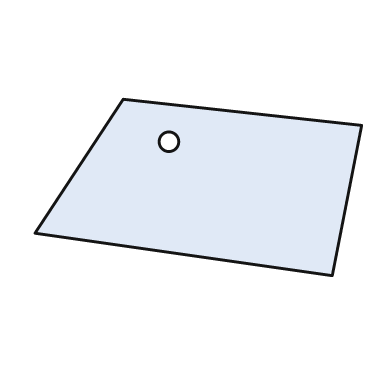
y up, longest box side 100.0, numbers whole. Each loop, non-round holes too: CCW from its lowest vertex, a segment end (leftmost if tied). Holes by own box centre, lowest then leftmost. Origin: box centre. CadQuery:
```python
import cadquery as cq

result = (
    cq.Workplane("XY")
    .moveTo(41.0, -27.0)
    .lineTo(50.0, 19.0)
    .lineTo(-23.0, 27.0)
    .lineTo(-50.0, -14.0)
    .close()
    .moveTo(-9.0, 14.0)
    .circle(3.0)
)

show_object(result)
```